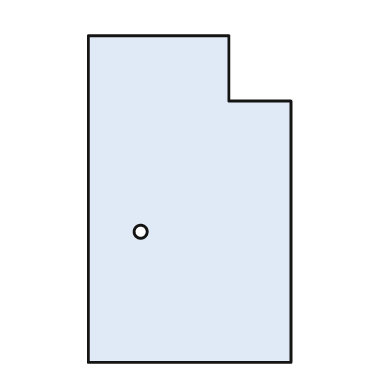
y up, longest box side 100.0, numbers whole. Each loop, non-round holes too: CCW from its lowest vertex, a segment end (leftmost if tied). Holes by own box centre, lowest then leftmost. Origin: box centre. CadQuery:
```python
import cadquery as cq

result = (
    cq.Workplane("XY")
    .moveTo(-31.0, -50.0)
    .lineTo(31.0, -50.0)
    .lineTo(31.0, 30.0)
    .lineTo(12.0, 30.0)
    .lineTo(12.0, 50.0)
    .lineTo(-31.0, 50.0)
    .close()
    .moveTo(-15.0, -10.0)
    .circle(2.0)
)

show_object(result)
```